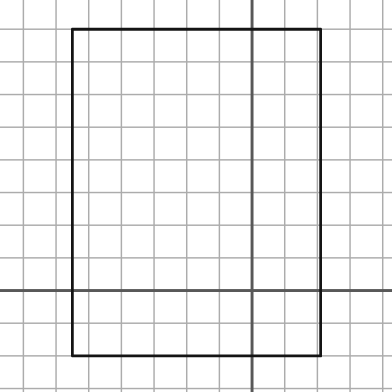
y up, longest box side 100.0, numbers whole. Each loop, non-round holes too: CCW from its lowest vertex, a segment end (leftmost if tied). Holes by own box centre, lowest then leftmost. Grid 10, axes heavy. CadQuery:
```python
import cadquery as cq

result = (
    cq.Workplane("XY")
    .moveTo(-55.0, -20.0)
    .lineTo(21.0, -20.0)
    .lineTo(21.0, 80.0)
    .lineTo(-55.0, 80.0)
    .close()
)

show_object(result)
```